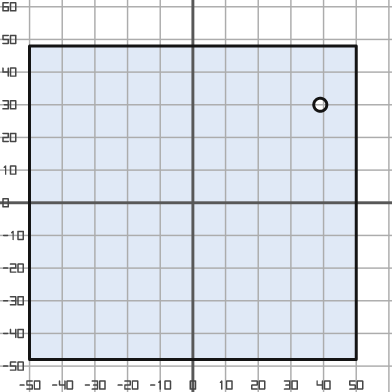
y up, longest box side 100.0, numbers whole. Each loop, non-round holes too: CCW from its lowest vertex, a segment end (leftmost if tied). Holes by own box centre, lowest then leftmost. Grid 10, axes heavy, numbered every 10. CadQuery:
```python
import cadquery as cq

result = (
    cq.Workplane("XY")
    .moveTo(-50.0, -48.0)
    .lineTo(50.0, -48.0)
    .lineTo(50.0, 48.0)
    .lineTo(-50.0, 48.0)
    .close()
    .moveTo(39.0, 30.0)
    .circle(2.0)
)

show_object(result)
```